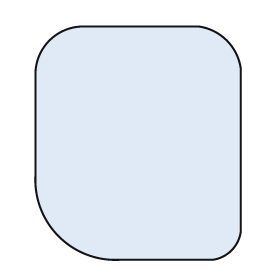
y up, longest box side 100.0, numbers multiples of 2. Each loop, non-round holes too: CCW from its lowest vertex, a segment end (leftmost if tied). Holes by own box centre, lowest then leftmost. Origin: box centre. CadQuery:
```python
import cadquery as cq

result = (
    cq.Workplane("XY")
    .moveTo(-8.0, -50.0)
    .lineTo(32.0, -50.0)
    .threePointArc((40.0, -46.0), (44.0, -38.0))
    .lineTo(44.0, 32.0)
    .threePointArc((38.0, 44.0), (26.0, 50.0))
    .lineTo(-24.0, 50.0)
    .threePointArc((-38.0, 44.0), (-44.0, 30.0))
    .lineTo(-44.0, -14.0)
    .threePointArc((-34.0, -40.0), (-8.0, -50.0))
    .close()
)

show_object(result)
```